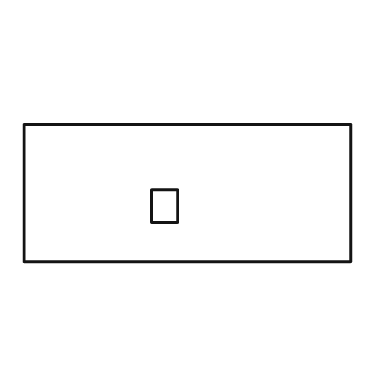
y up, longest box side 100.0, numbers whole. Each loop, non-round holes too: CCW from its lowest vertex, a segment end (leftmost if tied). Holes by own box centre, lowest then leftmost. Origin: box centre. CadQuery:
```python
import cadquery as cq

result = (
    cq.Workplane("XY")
    .moveTo(-50.0, -21.0)
    .lineTo(50.0, -21.0)
    .lineTo(50.0, 21.0)
    .lineTo(-50.0, 21.0)
    .close()
    .moveTo(-11.0, -9.0)
    .lineTo(-3.0, -9.0)
    .lineTo(-3.0, 1.0)
    .lineTo(-11.0, 1.0)
    .close()
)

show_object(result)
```